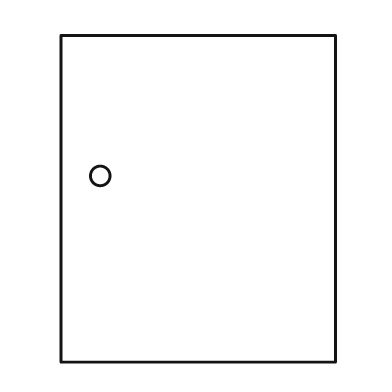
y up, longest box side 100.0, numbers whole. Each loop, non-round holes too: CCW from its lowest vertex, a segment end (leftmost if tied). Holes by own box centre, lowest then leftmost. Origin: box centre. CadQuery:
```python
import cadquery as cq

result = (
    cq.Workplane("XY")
    .moveTo(-42.0, -50.0)
    .lineTo(42.0, -50.0)
    .lineTo(42.0, 50.0)
    .lineTo(-42.0, 50.0)
    .close()
    .moveTo(-30.0, 7.0)
    .circle(3.0)
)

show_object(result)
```